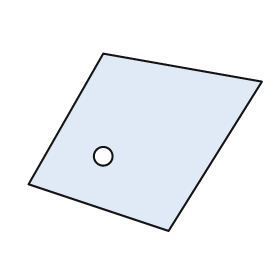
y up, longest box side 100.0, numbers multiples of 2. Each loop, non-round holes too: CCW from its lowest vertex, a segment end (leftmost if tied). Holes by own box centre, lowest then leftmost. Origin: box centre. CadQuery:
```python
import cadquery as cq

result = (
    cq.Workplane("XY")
    .moveTo(10.0, -38.0)
    .lineTo(50.0, 26.0)
    .lineTo(-18.0, 38.0)
    .lineTo(-50.0, -18.0)
    .close()
    .moveTo(-18.0, -6.0)
    .circle(4.0)
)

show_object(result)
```